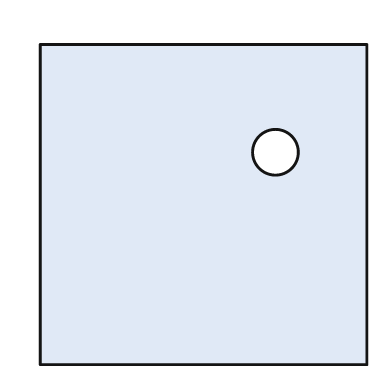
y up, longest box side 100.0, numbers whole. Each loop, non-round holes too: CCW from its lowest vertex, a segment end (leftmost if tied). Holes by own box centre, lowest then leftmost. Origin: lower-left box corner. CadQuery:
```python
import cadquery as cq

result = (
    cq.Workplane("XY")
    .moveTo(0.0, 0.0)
    .lineTo(100.0, 0.0)
    .lineTo(100.0, 98.0)
    .lineTo(0.0, 98.0)
    .close()
    .moveTo(72.0, 65.0)
    .circle(7.0)
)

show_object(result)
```